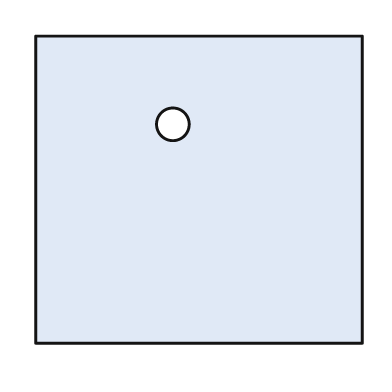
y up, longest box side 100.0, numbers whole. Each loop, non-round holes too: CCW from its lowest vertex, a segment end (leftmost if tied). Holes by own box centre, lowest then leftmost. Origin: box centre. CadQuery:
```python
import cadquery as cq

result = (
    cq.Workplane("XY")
    .moveTo(-50.0, -47.0)
    .lineTo(50.0, -47.0)
    .lineTo(50.0, 47.0)
    .lineTo(-50.0, 47.0)
    .close()
    .moveTo(-8.0, 20.0)
    .circle(5.0)
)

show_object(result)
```